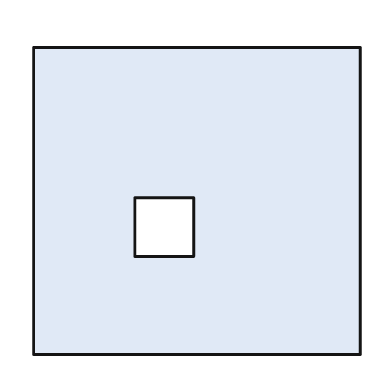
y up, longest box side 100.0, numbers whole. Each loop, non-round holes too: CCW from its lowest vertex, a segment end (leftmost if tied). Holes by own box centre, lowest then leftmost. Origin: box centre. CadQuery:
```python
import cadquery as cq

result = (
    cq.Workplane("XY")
    .moveTo(-50.0, -47.0)
    .lineTo(50.0, -47.0)
    .lineTo(50.0, 47.0)
    .lineTo(-50.0, 47.0)
    .close()
    .moveTo(-19.0, -17.0)
    .lineTo(-1.0, -17.0)
    .lineTo(-1.0, 1.0)
    .lineTo(-19.0, 1.0)
    .close()
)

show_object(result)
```